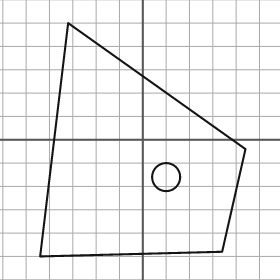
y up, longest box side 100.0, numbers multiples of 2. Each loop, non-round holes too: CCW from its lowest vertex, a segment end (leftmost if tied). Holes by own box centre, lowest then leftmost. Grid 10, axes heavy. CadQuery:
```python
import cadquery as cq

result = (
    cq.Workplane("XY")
    .moveTo(-44.0, -50.0)
    .lineTo(34.0, -48.0)
    .lineTo(44.0, -4.0)
    .lineTo(-32.0, 50.0)
    .close()
    .moveTo(10.0, -16.0)
    .circle(6.0)
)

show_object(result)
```